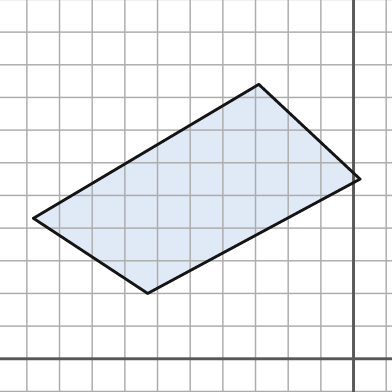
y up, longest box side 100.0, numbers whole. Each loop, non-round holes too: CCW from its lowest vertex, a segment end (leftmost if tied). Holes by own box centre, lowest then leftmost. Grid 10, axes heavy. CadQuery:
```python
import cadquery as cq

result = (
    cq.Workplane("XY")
    .moveTo(-63.0, 20.0)
    .lineTo(2.0, 55.0)
    .lineTo(-29.0, 84.0)
    .lineTo(-98.0, 43.0)
    .close()
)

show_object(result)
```